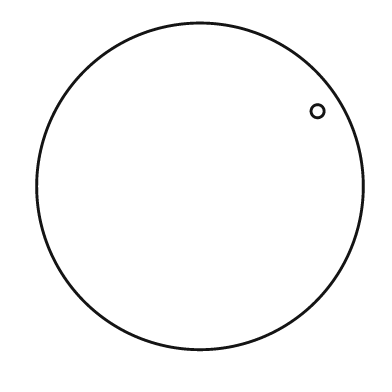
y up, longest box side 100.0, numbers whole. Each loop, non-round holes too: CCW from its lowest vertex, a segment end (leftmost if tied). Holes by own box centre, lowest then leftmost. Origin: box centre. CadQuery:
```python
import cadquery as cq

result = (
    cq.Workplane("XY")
    .moveTo(0.0, 0.0)
    .circle(50.0)
    .moveTo(36.0, 23.0)
    .circle(2.0)
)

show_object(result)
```